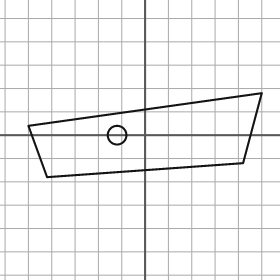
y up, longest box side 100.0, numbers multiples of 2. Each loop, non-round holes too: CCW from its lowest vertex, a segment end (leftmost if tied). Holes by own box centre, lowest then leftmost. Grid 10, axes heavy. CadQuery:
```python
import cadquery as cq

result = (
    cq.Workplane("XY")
    .moveTo(-42.0, -18.0)
    .lineTo(42.0, -12.0)
    .lineTo(50.0, 18.0)
    .lineTo(-50.0, 4.0)
    .close()
    .moveTo(-12.0, 0.0)
    .circle(4.0)
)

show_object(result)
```